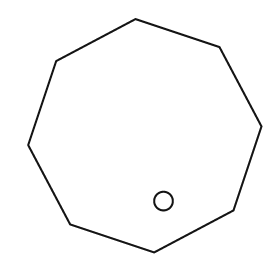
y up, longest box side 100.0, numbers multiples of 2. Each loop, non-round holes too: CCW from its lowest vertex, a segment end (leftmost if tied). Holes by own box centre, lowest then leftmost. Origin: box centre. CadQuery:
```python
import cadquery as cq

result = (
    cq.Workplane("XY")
    .moveTo(4.0, -50.0)
    .lineTo(38.0, -32.0)
    .lineTo(50.0, 4.0)
    .lineTo(32.0, 38.0)
    .lineTo(-4.0, 50.0)
    .lineTo(-38.0, 32.0)
    .lineTo(-50.0, -4.0)
    .lineTo(-32.0, -38.0)
    .close()
    .moveTo(8.0, -28.0)
    .circle(4.0)
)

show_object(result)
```